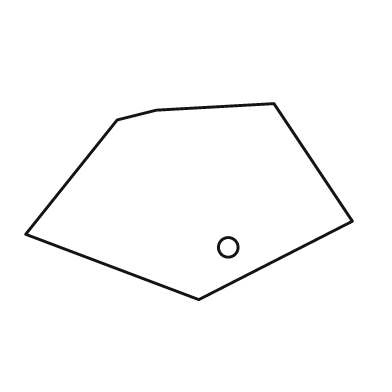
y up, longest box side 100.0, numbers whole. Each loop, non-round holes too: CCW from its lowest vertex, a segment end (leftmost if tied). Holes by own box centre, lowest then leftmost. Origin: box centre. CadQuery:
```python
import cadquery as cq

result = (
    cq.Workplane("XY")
    .moveTo(3.0, -30.0)
    .lineTo(50.0, -6.0)
    .lineTo(26.0, 30.0)
    .lineTo(-10.0, 28.0)
    .lineTo(-22.0, 25.0)
    .lineTo(-50.0, -10.0)
    .close()
    .moveTo(12.0, -14.0)
    .circle(3.0)
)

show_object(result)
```